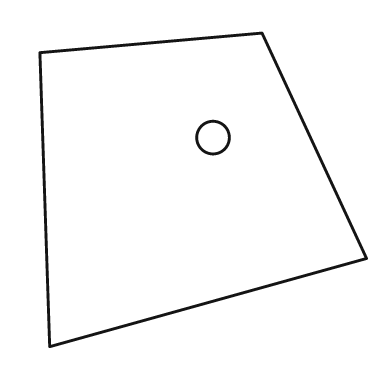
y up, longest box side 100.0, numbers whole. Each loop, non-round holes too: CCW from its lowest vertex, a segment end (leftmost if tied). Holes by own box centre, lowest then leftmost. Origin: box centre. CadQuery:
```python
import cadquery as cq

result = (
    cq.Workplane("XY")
    .moveTo(-47.0, -48.0)
    .lineTo(50.0, -21.0)
    .lineTo(18.0, 48.0)
    .lineTo(-50.0, 42.0)
    .close()
    .moveTo(3.0, 16.0)
    .circle(5.0)
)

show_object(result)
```